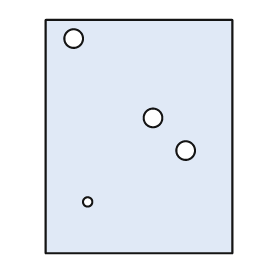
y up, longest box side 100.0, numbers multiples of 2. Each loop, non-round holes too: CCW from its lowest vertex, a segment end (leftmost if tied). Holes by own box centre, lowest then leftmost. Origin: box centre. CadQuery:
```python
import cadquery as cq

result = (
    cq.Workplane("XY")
    .moveTo(-40.0, -50.0)
    .lineTo(40.0, -50.0)
    .lineTo(40.0, 50.0)
    .lineTo(-40.0, 50.0)
    .close()
    .moveTo(-22.0, -28.0)
    .circle(2.0)
    .moveTo(20.0, -6.0)
    .circle(4.0)
    .moveTo(6.0, 8.0)
    .circle(4.0)
    .moveTo(-28.0, 42.0)
    .circle(4.0)
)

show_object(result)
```